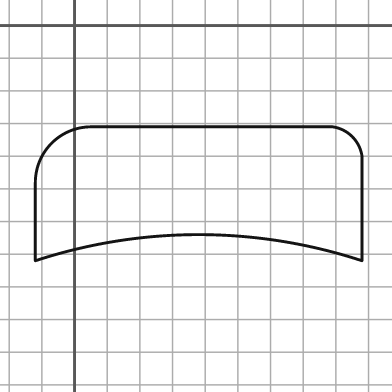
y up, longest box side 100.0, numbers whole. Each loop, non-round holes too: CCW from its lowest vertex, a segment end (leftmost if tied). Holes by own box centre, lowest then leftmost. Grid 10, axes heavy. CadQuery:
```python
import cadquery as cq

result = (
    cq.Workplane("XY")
    .moveTo(-12.0, -72.0)
    .threePointArc((38.0, -64.0), (88.0, -72.0))
    .lineTo(88.0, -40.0)
    .threePointArc((85.0, -34.0), (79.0, -31.0))
    .lineTo(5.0, -31.0)
    .threePointArc((-7.0, -36.0), (-12.0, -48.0))
    .close()
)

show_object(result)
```